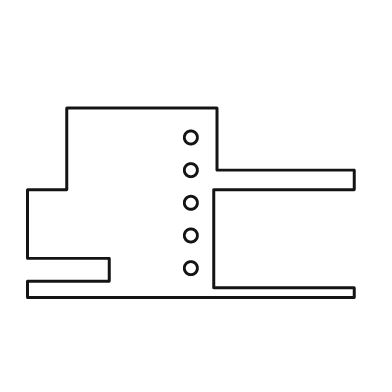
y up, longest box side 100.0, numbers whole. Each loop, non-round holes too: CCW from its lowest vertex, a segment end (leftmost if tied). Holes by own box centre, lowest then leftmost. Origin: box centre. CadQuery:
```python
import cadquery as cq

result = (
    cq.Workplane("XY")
    .moveTo(-50.0, -29.0)
    .lineTo(50.0, -29.0)
    .lineTo(50.0, -26.0)
    .lineTo(7.0, -26.0)
    .lineTo(7.0, 4.0)
    .lineTo(50.0, 4.0)
    .lineTo(50.0, 10.0)
    .lineTo(8.0, 10.0)
    .lineTo(8.0, 29.0)
    .lineTo(-38.0, 29.0)
    .lineTo(-38.0, 4.0)
    .lineTo(-50.0, 4.0)
    .lineTo(-50.0, -17.0)
    .lineTo(-25.0, -17.0)
    .lineTo(-25.0, -24.0)
    .lineTo(-50.0, -24.0)
    .close()
    .moveTo(0.0, -20.0)
    .circle(2.0)
    .moveTo(0.0, -10.0)
    .circle(2.0)
    .moveTo(0.0, 0.0)
    .circle(2.0)
    .moveTo(0.0, 10.0)
    .circle(2.0)
    .moveTo(0.0, 20.0)
    .circle(2.0)
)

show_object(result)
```